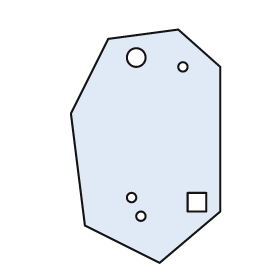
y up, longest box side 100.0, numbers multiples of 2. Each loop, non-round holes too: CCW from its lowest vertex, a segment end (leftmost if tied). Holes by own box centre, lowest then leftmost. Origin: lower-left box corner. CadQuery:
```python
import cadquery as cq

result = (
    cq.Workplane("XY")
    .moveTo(38.0, 0.0)
    .lineTo(64.0, 22.0)
    .lineTo(64.0, 84.0)
    .lineTo(46.0, 100.0)
    .lineTo(16.0, 96.0)
    .lineTo(0.0, 64.0)
    .lineTo(6.0, 16.0)
    .close()
    .moveTo(30.0, 20.0)
    .circle(2.0)
    .moveTo(50.0, 22.0)
    .lineTo(58.0, 22.0)
    .lineTo(58.0, 30.0)
    .lineTo(50.0, 30.0)
    .close()
    .moveTo(26.0, 28.0)
    .circle(2.0)
    .moveTo(48.0, 84.0)
    .circle(2.0)
    .moveTo(28.0, 88.0)
    .circle(4.0)
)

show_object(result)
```